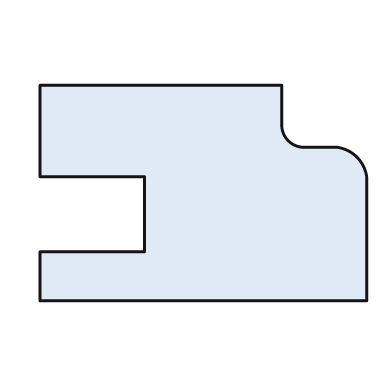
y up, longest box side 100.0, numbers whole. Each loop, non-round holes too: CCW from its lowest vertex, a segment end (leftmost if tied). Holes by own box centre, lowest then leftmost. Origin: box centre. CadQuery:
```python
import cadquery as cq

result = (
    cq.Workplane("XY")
    .moveTo(-50.0, -33.0)
    .lineTo(50.0, -33.0)
    .lineTo(50.0, 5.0)
    .threePointArc((47.0, 11.0), (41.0, 14.0))
    .lineTo(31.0, 14.0)
    .threePointArc((26.0, 16.0), (24.0, 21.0))
    .lineTo(24.0, 33.0)
    .lineTo(-50.0, 33.0)
    .lineTo(-50.0, 5.0)
    .lineTo(-18.0, 5.0)
    .lineTo(-18.0, -18.0)
    .lineTo(-50.0, -18.0)
    .close()
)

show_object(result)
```